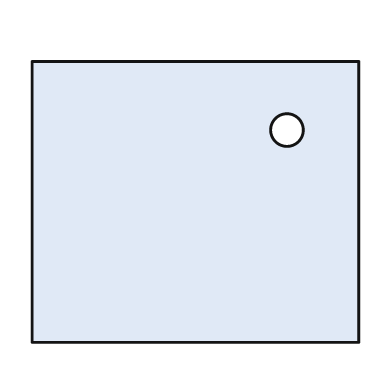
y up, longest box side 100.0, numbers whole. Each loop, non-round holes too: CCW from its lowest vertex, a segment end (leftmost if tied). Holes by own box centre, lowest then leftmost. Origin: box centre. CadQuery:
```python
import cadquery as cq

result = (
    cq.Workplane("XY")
    .moveTo(-50.0, -43.0)
    .lineTo(50.0, -43.0)
    .lineTo(50.0, 43.0)
    .lineTo(-50.0, 43.0)
    .close()
    .moveTo(28.0, 22.0)
    .circle(5.0)
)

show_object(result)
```